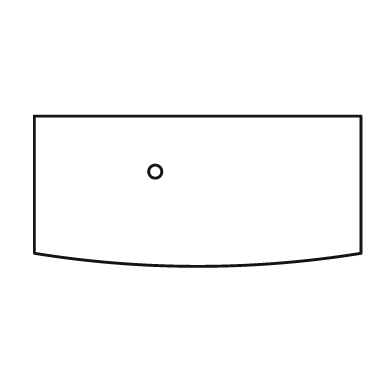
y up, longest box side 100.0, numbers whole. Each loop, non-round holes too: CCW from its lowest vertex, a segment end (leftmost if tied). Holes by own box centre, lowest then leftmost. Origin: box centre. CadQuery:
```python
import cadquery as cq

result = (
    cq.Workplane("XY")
    .moveTo(-50.0, -19.0)
    .threePointArc((0.0, -23.0), (50.0, -19.0))
    .lineTo(50.0, 23.0)
    .lineTo(-50.0, 23.0)
    .close()
    .moveTo(-13.0, 6.0)
    .circle(2.0)
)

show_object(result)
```